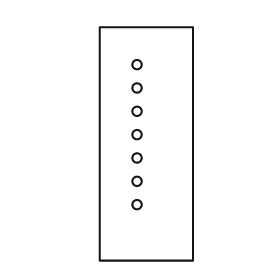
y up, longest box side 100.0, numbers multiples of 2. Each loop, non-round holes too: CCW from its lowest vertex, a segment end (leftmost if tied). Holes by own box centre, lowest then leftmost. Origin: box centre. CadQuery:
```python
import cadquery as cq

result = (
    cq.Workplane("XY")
    .moveTo(-20.0, -50.0)
    .lineTo(20.0, -50.0)
    .lineTo(20.0, 50.0)
    .lineTo(-20.0, 50.0)
    .close()
    .moveTo(-4.0, -26.0)
    .circle(2.0)
    .moveTo(-4.0, -16.0)
    .circle(2.0)
    .moveTo(-4.0, -6.0)
    .circle(2.0)
    .moveTo(-4.0, 4.0)
    .circle(2.0)
    .moveTo(-4.0, 14.0)
    .circle(2.0)
    .moveTo(-4.0, 24.0)
    .circle(2.0)
    .moveTo(-4.0, 34.0)
    .circle(2.0)
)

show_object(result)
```